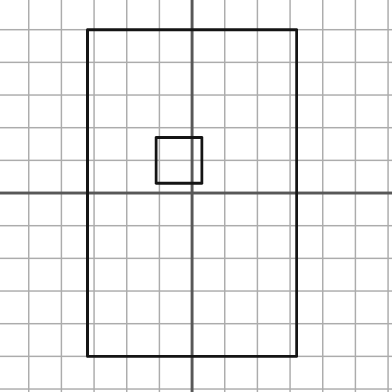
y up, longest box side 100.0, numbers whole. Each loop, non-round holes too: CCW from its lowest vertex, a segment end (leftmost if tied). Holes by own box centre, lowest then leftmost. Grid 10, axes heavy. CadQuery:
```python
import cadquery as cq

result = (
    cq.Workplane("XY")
    .moveTo(-32.0, -50.0)
    .lineTo(32.0, -50.0)
    .lineTo(32.0, 50.0)
    .lineTo(-32.0, 50.0)
    .close()
    .moveTo(-11.0, 3.0)
    .lineTo(3.0, 3.0)
    .lineTo(3.0, 17.0)
    .lineTo(-11.0, 17.0)
    .close()
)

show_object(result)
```